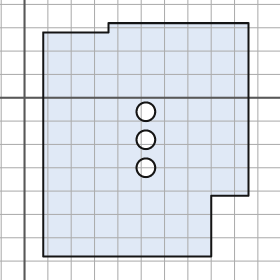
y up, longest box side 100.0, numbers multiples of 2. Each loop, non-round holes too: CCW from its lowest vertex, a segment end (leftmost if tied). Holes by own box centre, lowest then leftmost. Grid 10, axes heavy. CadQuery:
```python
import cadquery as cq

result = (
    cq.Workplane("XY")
    .moveTo(8.0, -68.0)
    .lineTo(80.0, -68.0)
    .lineTo(80.0, -42.0)
    .lineTo(96.0, -42.0)
    .lineTo(96.0, 32.0)
    .lineTo(36.0, 32.0)
    .lineTo(36.0, 28.0)
    .lineTo(8.0, 28.0)
    .close()
    .moveTo(52.0, -30.0)
    .circle(4.0)
    .moveTo(52.0, -18.0)
    .circle(4.0)
    .moveTo(52.0, -6.0)
    .circle(4.0)
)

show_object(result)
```